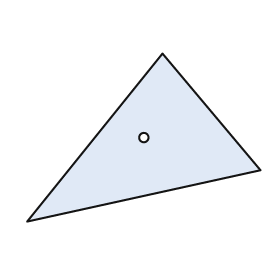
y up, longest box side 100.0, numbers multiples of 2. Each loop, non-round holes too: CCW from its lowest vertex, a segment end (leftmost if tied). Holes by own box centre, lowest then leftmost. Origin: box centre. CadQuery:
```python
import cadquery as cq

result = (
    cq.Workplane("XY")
    .moveTo(-50.0, -36.0)
    .lineTo(50.0, -14.0)
    .lineTo(8.0, 36.0)
    .close()
    .moveTo(0.0, 0.0)
    .circle(2.0)
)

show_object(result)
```